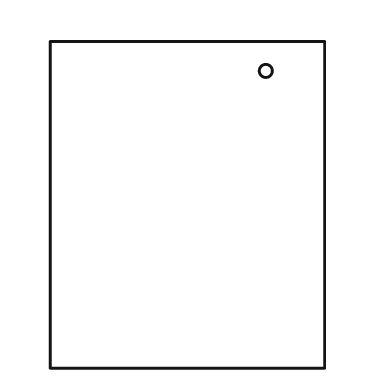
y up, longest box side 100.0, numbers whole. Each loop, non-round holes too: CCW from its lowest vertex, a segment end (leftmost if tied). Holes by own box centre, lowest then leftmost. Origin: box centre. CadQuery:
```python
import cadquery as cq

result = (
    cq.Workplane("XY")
    .moveTo(-42.0, -50.0)
    .lineTo(42.0, -50.0)
    .lineTo(42.0, 50.0)
    .lineTo(-42.0, 50.0)
    .close()
    .moveTo(24.0, 41.0)
    .circle(2.0)
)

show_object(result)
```